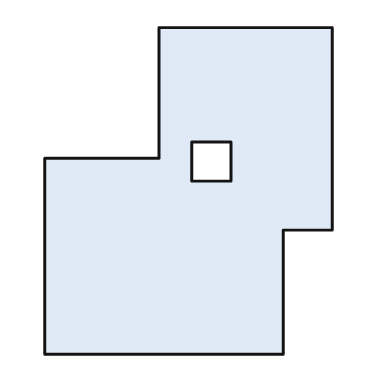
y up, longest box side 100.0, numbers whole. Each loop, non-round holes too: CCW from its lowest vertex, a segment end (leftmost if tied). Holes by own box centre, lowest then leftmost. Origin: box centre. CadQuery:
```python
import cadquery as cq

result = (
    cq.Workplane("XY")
    .moveTo(-44.0, -50.0)
    .lineTo(29.0, -50.0)
    .lineTo(29.0, -12.0)
    .lineTo(44.0, -12.0)
    .lineTo(44.0, 50.0)
    .lineTo(-9.0, 50.0)
    .lineTo(-9.0, 10.0)
    .lineTo(-44.0, 10.0)
    .close()
    .moveTo(1.0, 3.0)
    .lineTo(13.0, 3.0)
    .lineTo(13.0, 15.0)
    .lineTo(1.0, 15.0)
    .close()
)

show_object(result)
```